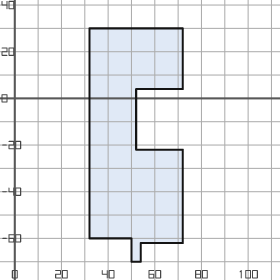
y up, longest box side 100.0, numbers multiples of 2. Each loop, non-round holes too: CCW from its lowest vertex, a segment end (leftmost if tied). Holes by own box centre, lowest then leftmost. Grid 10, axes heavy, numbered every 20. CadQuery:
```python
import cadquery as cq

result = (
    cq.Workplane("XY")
    .moveTo(50.0, -70.0)
    .lineTo(54.0, -70.0)
    .lineTo(54.0, -62.0)
    .lineTo(72.0, -62.0)
    .lineTo(72.0, -22.0)
    .lineTo(52.0, -22.0)
    .lineTo(52.0, 4.0)
    .lineTo(72.0, 4.0)
    .lineTo(72.0, 30.0)
    .lineTo(32.0, 30.0)
    .lineTo(32.0, -60.0)
    .lineTo(50.0, -60.0)
    .close()
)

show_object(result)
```